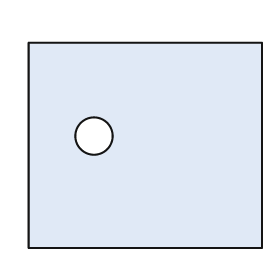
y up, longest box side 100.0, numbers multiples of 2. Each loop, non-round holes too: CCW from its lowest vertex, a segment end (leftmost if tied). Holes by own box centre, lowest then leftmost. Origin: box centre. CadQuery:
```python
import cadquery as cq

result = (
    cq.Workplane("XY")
    .moveTo(-50.0, -44.0)
    .lineTo(50.0, -44.0)
    .lineTo(50.0, 44.0)
    .lineTo(-50.0, 44.0)
    .close()
    .moveTo(-22.0, 4.0)
    .circle(8.0)
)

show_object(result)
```